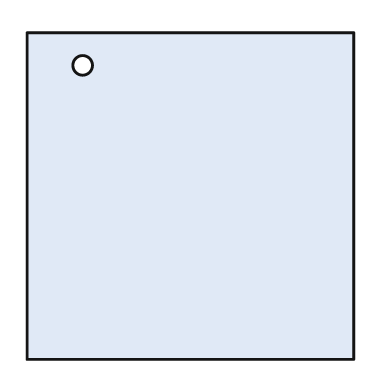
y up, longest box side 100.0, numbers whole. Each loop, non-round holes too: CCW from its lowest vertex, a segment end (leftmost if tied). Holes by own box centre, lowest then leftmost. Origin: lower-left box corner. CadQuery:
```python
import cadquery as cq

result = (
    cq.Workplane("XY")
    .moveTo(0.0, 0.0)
    .lineTo(100.0, 0.0)
    .lineTo(100.0, 100.0)
    .lineTo(0.0, 100.0)
    .close()
    .moveTo(17.0, 90.0)
    .circle(3.0)
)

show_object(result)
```